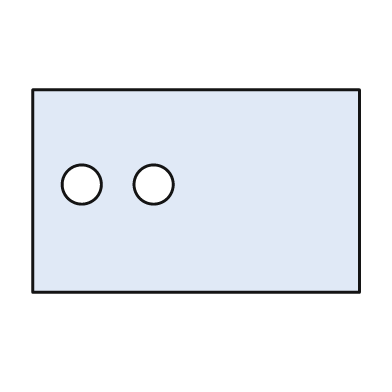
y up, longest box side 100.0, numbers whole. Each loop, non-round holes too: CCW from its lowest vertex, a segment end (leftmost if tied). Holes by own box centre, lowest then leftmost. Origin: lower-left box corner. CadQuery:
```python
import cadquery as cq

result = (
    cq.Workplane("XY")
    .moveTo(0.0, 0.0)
    .lineTo(100.0, 0.0)
    .lineTo(100.0, 62.0)
    .lineTo(0.0, 62.0)
    .close()
    .moveTo(15.0, 33.0)
    .circle(6.0)
    .moveTo(37.0, 33.0)
    .circle(6.0)
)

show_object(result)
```